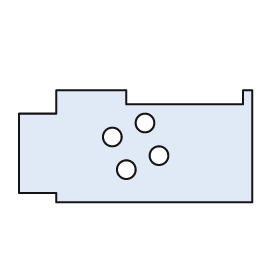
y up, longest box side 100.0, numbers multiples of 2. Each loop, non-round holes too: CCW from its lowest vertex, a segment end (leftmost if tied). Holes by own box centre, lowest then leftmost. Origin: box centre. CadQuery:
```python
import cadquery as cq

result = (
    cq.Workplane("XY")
    .moveTo(-34.0, -24.0)
    .lineTo(50.0, -24.0)
    .lineTo(50.0, 24.0)
    .lineTo(46.0, 24.0)
    .lineTo(46.0, 18.0)
    .lineTo(-4.0, 18.0)
    .lineTo(-4.0, 24.0)
    .lineTo(-34.0, 24.0)
    .lineTo(-34.0, 14.0)
    .lineTo(-50.0, 14.0)
    .lineTo(-50.0, -20.0)
    .lineTo(-34.0, -20.0)
    .close()
    .moveTo(-4.0, -10.0)
    .circle(4.0)
    .moveTo(10.0, -4.0)
    .circle(4.0)
    .moveTo(-10.0, 4.0)
    .circle(4.0)
    .moveTo(4.0, 10.0)
    .circle(4.0)
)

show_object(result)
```